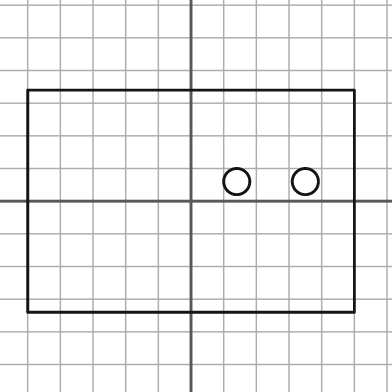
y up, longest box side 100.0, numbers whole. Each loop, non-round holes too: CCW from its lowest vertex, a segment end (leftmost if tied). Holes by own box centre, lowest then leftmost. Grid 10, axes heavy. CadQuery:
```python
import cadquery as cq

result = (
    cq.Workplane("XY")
    .moveTo(-50.0, -34.0)
    .lineTo(50.0, -34.0)
    .lineTo(50.0, 34.0)
    .lineTo(-50.0, 34.0)
    .close()
    .moveTo(14.0, 6.0)
    .circle(4.0)
    .moveTo(35.0, 6.0)
    .circle(4.0)
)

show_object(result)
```